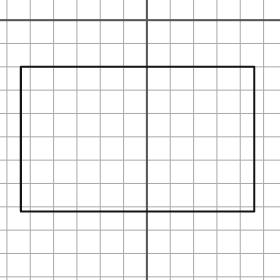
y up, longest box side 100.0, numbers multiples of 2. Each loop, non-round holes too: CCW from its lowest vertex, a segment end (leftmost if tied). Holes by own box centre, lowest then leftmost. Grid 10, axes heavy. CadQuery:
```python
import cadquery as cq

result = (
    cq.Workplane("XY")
    .moveTo(-54.0, -82.0)
    .lineTo(46.0, -82.0)
    .lineTo(46.0, -20.0)
    .lineTo(-54.0, -20.0)
    .close()
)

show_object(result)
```